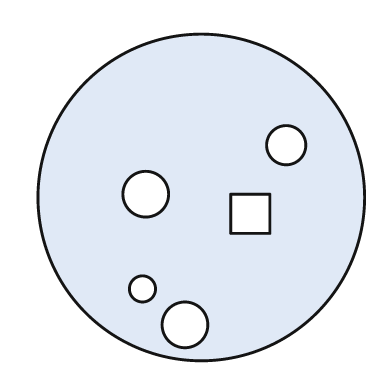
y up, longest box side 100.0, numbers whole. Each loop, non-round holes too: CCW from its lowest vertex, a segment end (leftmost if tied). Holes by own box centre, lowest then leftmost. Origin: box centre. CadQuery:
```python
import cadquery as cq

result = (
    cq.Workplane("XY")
    .moveTo(0.0, 0.0)
    .circle(50.0)
    .moveTo(-5.0, -39.0)
    .circle(7.0)
    .moveTo(-18.0, -28.0)
    .circle(4.0)
    .moveTo(9.0, -11.0)
    .lineTo(21.0, -11.0)
    .lineTo(21.0, 1.0)
    .lineTo(9.0, 1.0)
    .close()
    .moveTo(-17.0, 1.0)
    .circle(7.0)
    .moveTo(26.0, 16.0)
    .circle(6.0)
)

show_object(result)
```